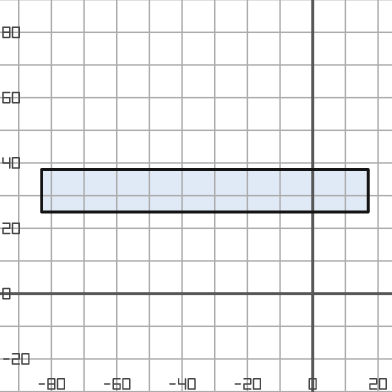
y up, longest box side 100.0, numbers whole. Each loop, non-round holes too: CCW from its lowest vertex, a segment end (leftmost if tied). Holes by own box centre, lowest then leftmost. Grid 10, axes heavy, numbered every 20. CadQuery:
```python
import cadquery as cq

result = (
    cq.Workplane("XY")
    .moveTo(-83.0, 25.0)
    .lineTo(17.0, 25.0)
    .lineTo(17.0, 38.0)
    .lineTo(-83.0, 38.0)
    .close()
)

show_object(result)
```